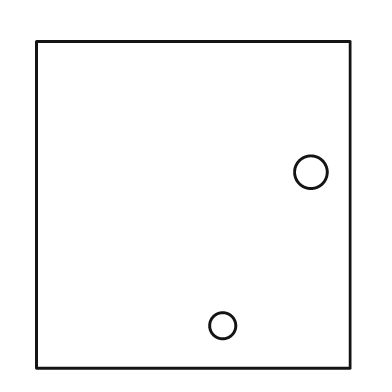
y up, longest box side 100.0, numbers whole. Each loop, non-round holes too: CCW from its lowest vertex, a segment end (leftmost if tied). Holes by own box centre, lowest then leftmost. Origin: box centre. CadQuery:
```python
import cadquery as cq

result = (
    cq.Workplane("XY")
    .moveTo(-48.0, -50.0)
    .lineTo(48.0, -50.0)
    .lineTo(48.0, 50.0)
    .lineTo(-48.0, 50.0)
    .close()
    .moveTo(9.0, -37.0)
    .circle(4.0)
    .moveTo(36.0, 10.0)
    .circle(5.0)
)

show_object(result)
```